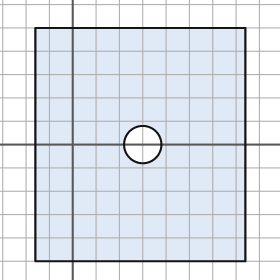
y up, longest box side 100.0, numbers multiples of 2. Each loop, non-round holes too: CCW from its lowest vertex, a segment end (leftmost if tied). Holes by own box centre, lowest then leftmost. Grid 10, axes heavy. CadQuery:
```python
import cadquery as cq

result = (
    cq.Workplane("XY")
    .moveTo(-16.0, -50.0)
    .lineTo(74.0, -50.0)
    .lineTo(74.0, 50.0)
    .lineTo(-16.0, 50.0)
    .close()
    .moveTo(30.0, 0.0)
    .circle(8.0)
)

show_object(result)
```